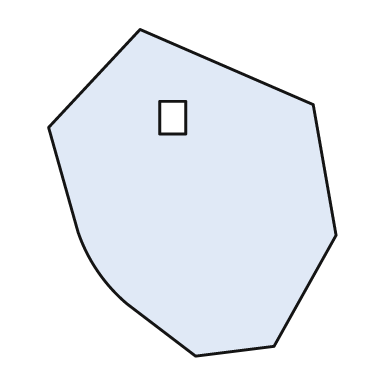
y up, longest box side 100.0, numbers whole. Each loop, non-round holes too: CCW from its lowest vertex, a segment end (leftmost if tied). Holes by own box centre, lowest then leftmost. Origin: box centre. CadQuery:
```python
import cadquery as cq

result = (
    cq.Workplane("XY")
    .moveTo(1.0, -50.0)
    .lineTo(25.0, -47.0)
    .lineTo(44.0, -13.0)
    .lineTo(37.0, 27.0)
    .lineTo(-16.0, 50.0)
    .lineTo(-44.0, 20.0)
    .lineTo(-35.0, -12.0)
    .threePointArc((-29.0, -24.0), (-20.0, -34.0))
    .close()
    .moveTo(-10.0, 18.0)
    .lineTo(-2.0, 18.0)
    .lineTo(-2.0, 28.0)
    .lineTo(-10.0, 28.0)
    .close()
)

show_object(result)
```